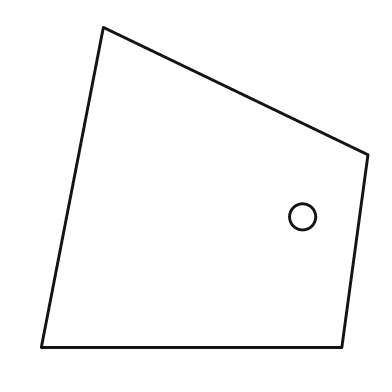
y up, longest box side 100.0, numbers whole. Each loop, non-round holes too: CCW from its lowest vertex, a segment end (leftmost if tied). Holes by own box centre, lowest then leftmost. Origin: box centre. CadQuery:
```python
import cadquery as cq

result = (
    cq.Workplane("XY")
    .moveTo(-50.0, -49.0)
    .lineTo(42.0, -49.0)
    .lineTo(50.0, 10.0)
    .lineTo(-31.0, 49.0)
    .close()
    .moveTo(30.0, -9.0)
    .circle(4.0)
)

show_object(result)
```